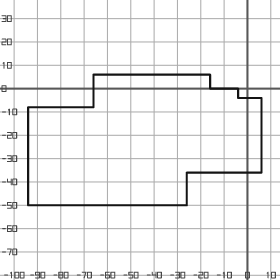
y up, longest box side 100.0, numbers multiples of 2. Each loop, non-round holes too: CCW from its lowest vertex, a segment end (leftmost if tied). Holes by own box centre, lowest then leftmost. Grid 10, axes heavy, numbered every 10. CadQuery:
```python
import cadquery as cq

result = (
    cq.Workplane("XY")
    .moveTo(-94.0, -50.0)
    .lineTo(-26.0, -50.0)
    .lineTo(-26.0, -36.0)
    .lineTo(6.0, -36.0)
    .lineTo(6.0, -4.0)
    .lineTo(-4.0, -4.0)
    .lineTo(-4.0, 0.0)
    .lineTo(-16.0, 0.0)
    .lineTo(-16.0, 6.0)
    .lineTo(-66.0, 6.0)
    .lineTo(-66.0, -8.0)
    .lineTo(-94.0, -8.0)
    .close()
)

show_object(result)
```